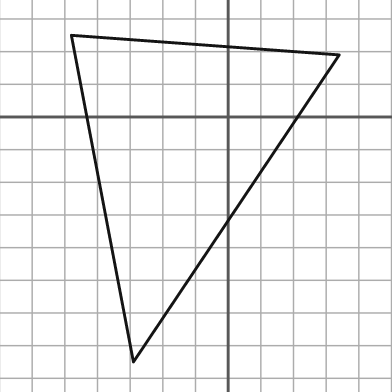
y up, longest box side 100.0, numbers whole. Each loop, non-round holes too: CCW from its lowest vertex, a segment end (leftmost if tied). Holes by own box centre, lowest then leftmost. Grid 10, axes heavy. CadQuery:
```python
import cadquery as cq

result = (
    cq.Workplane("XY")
    .moveTo(-29.0, -75.0)
    .lineTo(34.0, 19.0)
    .lineTo(-48.0, 25.0)
    .close()
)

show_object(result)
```